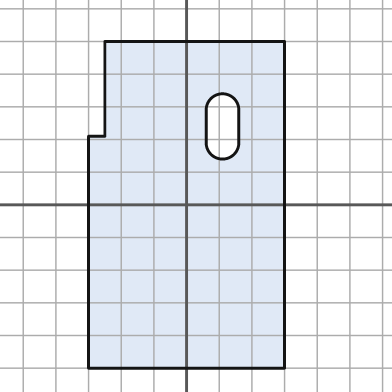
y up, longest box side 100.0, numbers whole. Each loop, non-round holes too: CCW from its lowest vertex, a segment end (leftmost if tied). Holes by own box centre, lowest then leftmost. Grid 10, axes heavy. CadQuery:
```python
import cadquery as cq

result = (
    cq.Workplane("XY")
    .moveTo(-30.0, -50.0)
    .lineTo(30.0, -50.0)
    .lineTo(30.0, 50.0)
    .lineTo(-25.0, 50.0)
    .lineTo(-25.0, 21.0)
    .lineTo(-30.0, 21.0)
    .close()
    .moveTo(6.0, 19.0)
    .threePointArc((11.0, 14.0), (16.0, 19.0))
    .lineTo(16.0, 29.0)
    .threePointArc((11.0, 34.0), (6.0, 29.0))
    .close()
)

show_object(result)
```